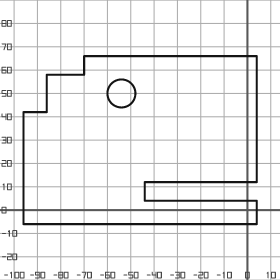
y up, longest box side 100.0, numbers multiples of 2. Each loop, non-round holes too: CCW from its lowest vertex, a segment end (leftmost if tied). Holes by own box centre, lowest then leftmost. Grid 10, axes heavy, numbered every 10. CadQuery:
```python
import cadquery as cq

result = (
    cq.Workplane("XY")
    .moveTo(-96.0, -6.0)
    .lineTo(4.0, -6.0)
    .lineTo(4.0, 4.0)
    .lineTo(-44.0, 4.0)
    .lineTo(-44.0, 12.0)
    .lineTo(4.0, 12.0)
    .lineTo(4.0, 66.0)
    .lineTo(-70.0, 66.0)
    .lineTo(-70.0, 58.0)
    .lineTo(-86.0, 58.0)
    .lineTo(-86.0, 42.0)
    .lineTo(-96.0, 42.0)
    .close()
    .moveTo(-54.0, 50.0)
    .circle(6.0)
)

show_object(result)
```